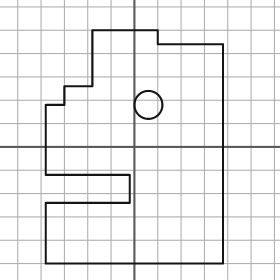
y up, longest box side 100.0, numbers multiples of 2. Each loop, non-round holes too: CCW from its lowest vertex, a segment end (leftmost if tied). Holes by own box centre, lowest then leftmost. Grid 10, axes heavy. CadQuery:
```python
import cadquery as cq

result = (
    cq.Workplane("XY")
    .moveTo(-38.0, -50.0)
    .lineTo(38.0, -50.0)
    .lineTo(38.0, 44.0)
    .lineTo(10.0, 44.0)
    .lineTo(10.0, 50.0)
    .lineTo(-18.0, 50.0)
    .lineTo(-18.0, 26.0)
    .lineTo(-30.0, 26.0)
    .lineTo(-30.0, 18.0)
    .lineTo(-38.0, 18.0)
    .lineTo(-38.0, -12.0)
    .lineTo(-2.0, -12.0)
    .lineTo(-2.0, -24.0)
    .lineTo(-38.0, -24.0)
    .close()
    .moveTo(6.0, 18.0)
    .circle(6.0)
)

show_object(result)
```